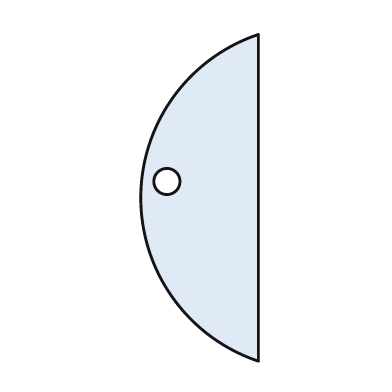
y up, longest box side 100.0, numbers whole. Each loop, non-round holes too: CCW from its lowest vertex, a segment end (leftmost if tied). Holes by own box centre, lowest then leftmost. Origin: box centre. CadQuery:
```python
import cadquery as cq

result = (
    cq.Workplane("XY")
    .moveTo(18.0, -50.0)
    .lineTo(18.0, 50.0)
    .threePointArc((-18.0, 0.0), (18.0, -50.0))
    .close()
    .moveTo(-10.0, 5.0)
    .circle(4.0)
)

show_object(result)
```